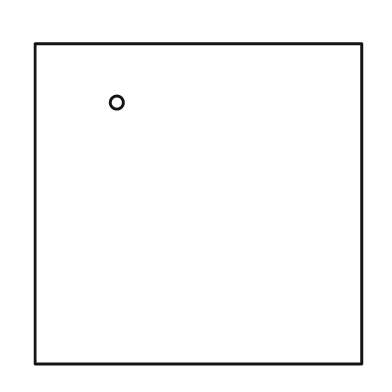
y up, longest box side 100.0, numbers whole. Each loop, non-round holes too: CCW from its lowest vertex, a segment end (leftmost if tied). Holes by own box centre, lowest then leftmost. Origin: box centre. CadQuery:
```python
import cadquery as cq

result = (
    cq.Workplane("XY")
    .moveTo(-50.0, -49.0)
    .lineTo(50.0, -49.0)
    .lineTo(50.0, 49.0)
    .lineTo(-50.0, 49.0)
    .close()
    .moveTo(-25.0, 31.0)
    .circle(2.0)
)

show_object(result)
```